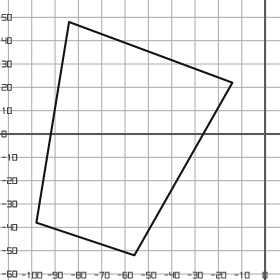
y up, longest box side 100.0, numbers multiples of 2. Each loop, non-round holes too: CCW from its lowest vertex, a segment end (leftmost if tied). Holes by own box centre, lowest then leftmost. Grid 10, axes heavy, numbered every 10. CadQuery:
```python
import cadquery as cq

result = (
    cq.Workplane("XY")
    .moveTo(-56.0, -52.0)
    .lineTo(-14.0, 22.0)
    .lineTo(-84.0, 48.0)
    .lineTo(-98.0, -38.0)
    .close()
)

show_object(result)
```